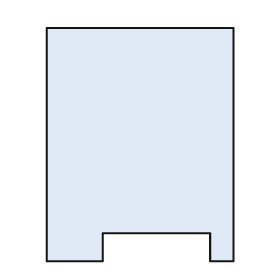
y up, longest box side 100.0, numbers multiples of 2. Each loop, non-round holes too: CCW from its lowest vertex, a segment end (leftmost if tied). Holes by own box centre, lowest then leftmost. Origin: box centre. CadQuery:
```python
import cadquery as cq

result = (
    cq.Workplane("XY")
    .moveTo(-40.0, -50.0)
    .lineTo(-16.0, -50.0)
    .lineTo(-16.0, -38.0)
    .lineTo(30.0, -38.0)
    .lineTo(30.0, -50.0)
    .lineTo(40.0, -50.0)
    .lineTo(40.0, 50.0)
    .lineTo(-40.0, 50.0)
    .close()
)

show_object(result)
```